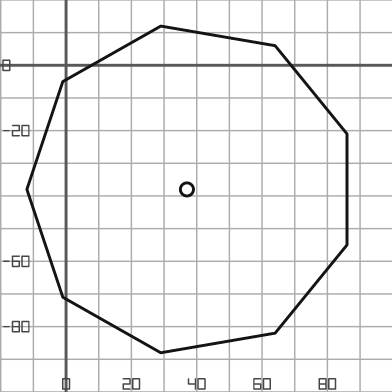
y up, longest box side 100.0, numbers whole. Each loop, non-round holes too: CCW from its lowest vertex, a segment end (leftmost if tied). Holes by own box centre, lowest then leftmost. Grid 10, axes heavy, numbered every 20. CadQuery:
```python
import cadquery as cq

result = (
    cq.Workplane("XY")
    .moveTo(29.0, -88.0)
    .lineTo(64.0, -82.0)
    .lineTo(86.0, -55.0)
    .lineTo(86.0, -21.0)
    .lineTo(64.0, 6.0)
    .lineTo(29.0, 12.0)
    .lineTo(-1.0, -5.0)
    .lineTo(-12.0, -38.0)
    .lineTo(-1.0, -71.0)
    .close()
    .moveTo(37.0, -38.0)
    .circle(2.0)
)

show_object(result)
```